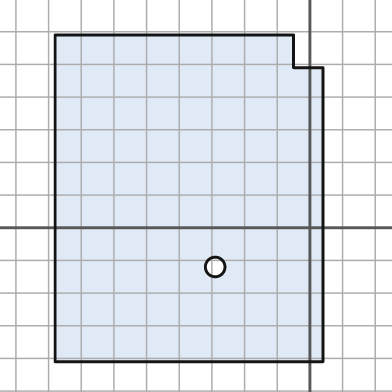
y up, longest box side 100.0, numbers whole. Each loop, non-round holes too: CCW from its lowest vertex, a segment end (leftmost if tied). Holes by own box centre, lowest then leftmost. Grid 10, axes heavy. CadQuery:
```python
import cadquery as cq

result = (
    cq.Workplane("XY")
    .moveTo(-78.0, -41.0)
    .lineTo(4.0, -41.0)
    .lineTo(4.0, 49.0)
    .lineTo(-5.0, 49.0)
    .lineTo(-5.0, 59.0)
    .lineTo(-78.0, 59.0)
    .close()
    .moveTo(-29.0, -12.0)
    .circle(3.0)
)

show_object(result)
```